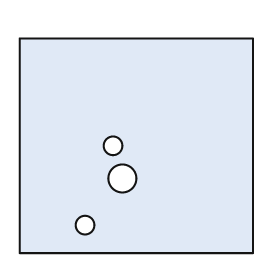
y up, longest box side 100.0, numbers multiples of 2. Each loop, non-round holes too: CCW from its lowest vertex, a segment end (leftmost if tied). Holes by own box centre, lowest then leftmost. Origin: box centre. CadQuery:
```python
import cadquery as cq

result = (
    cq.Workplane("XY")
    .moveTo(-50.0, -46.0)
    .lineTo(50.0, -46.0)
    .lineTo(50.0, 46.0)
    .lineTo(-50.0, 46.0)
    .close()
    .moveTo(-22.0, -34.0)
    .circle(4.0)
    .moveTo(-6.0, -14.0)
    .circle(6.0)
    .moveTo(-10.0, 0.0)
    .circle(4.0)
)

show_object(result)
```